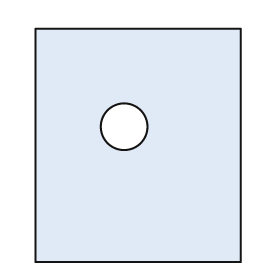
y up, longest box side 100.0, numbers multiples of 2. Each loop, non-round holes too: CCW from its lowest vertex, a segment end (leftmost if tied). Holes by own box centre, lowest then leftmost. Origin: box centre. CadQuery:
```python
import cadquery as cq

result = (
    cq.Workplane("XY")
    .moveTo(-44.0, -50.0)
    .lineTo(44.0, -50.0)
    .lineTo(44.0, 50.0)
    .lineTo(-44.0, 50.0)
    .close()
    .moveTo(-6.0, 8.0)
    .circle(10.0)
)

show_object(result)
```